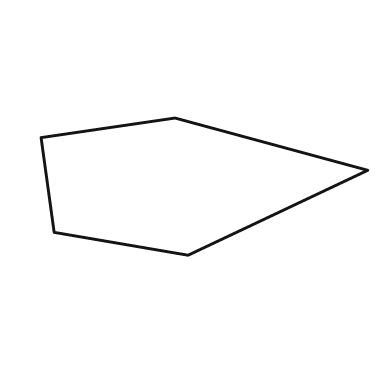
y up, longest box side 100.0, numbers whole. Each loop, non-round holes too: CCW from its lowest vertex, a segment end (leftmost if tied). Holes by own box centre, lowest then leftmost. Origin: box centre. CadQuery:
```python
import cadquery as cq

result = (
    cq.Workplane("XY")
    .moveTo(-5.0, -21.0)
    .lineTo(50.0, 5.0)
    .lineTo(-9.0, 21.0)
    .lineTo(-50.0, 15.0)
    .lineTo(-46.0, -14.0)
    .close()
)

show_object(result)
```